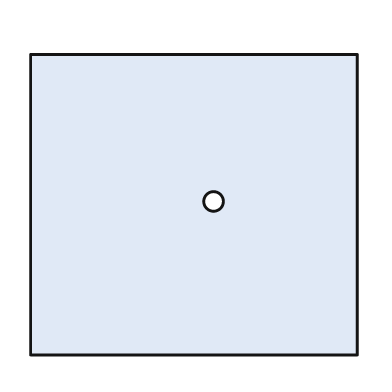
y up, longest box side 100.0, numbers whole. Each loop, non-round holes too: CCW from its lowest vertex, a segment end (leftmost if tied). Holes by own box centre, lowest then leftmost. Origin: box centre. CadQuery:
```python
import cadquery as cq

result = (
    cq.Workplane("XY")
    .moveTo(-50.0, -46.0)
    .lineTo(50.0, -46.0)
    .lineTo(50.0, 46.0)
    .lineTo(-50.0, 46.0)
    .close()
    .moveTo(6.0, 1.0)
    .circle(3.0)
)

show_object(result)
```